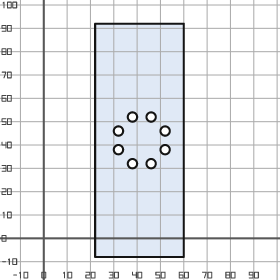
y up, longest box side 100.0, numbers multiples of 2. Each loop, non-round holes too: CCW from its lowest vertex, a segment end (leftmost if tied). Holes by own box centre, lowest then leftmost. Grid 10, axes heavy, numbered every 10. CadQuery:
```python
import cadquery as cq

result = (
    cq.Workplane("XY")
    .moveTo(22.0, -8.0)
    .lineTo(60.0, -8.0)
    .lineTo(60.0, 92.0)
    .lineTo(22.0, 92.0)
    .close()
    .moveTo(38.0, 32.0)
    .circle(2.0)
    .moveTo(46.0, 32.0)
    .circle(2.0)
    .moveTo(32.0, 38.0)
    .circle(2.0)
    .moveTo(52.0, 38.0)
    .circle(2.0)
    .moveTo(32.0, 46.0)
    .circle(2.0)
    .moveTo(52.0, 46.0)
    .circle(2.0)
    .moveTo(38.0, 52.0)
    .circle(2.0)
    .moveTo(46.0, 52.0)
    .circle(2.0)
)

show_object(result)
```